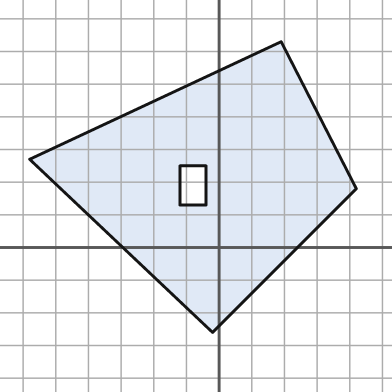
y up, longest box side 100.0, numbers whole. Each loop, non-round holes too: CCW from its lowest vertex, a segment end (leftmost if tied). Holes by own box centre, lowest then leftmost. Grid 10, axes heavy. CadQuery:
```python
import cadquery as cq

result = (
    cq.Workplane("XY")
    .moveTo(-2.0, -26.0)
    .lineTo(42.0, 18.0)
    .lineTo(19.0, 63.0)
    .lineTo(-58.0, 27.0)
    .close()
    .moveTo(-12.0, 13.0)
    .lineTo(-4.0, 13.0)
    .lineTo(-4.0, 25.0)
    .lineTo(-12.0, 25.0)
    .close()
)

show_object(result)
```